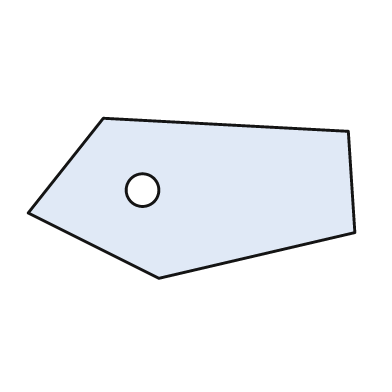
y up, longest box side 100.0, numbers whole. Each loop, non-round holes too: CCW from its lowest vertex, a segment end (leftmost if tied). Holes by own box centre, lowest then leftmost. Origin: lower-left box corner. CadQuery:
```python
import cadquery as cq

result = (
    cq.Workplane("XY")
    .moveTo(40.0, 0.0)
    .lineTo(100.0, 14.0)
    .lineTo(98.0, 45.0)
    .lineTo(23.0, 49.0)
    .lineTo(0.0, 20.0)
    .close()
    .moveTo(35.0, 27.0)
    .circle(5.0)
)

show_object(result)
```